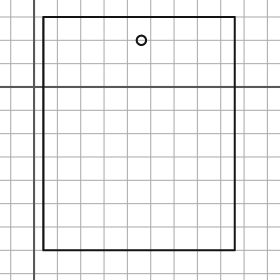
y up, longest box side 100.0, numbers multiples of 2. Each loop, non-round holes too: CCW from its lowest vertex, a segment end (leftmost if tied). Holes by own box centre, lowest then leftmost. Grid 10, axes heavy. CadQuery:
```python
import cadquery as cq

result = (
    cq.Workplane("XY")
    .moveTo(4.0, -70.0)
    .lineTo(86.0, -70.0)
    .lineTo(86.0, 30.0)
    .lineTo(4.0, 30.0)
    .close()
    .moveTo(46.0, 20.0)
    .circle(2.0)
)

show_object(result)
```